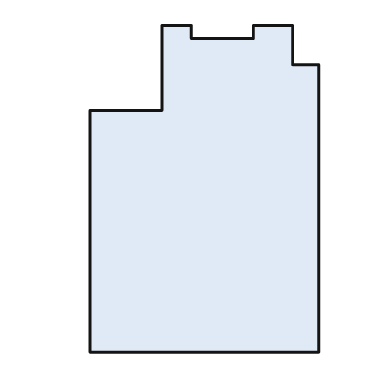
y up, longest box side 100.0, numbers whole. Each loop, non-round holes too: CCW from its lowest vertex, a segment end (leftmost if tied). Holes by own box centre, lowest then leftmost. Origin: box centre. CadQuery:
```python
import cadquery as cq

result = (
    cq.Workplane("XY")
    .moveTo(-35.0, -50.0)
    .lineTo(35.0, -50.0)
    .lineTo(35.0, 38.0)
    .lineTo(27.0, 38.0)
    .lineTo(27.0, 50.0)
    .lineTo(15.0, 50.0)
    .lineTo(15.0, 46.0)
    .lineTo(-4.0, 46.0)
    .lineTo(-4.0, 50.0)
    .lineTo(-13.0, 50.0)
    .lineTo(-13.0, 24.0)
    .lineTo(-35.0, 24.0)
    .close()
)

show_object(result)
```